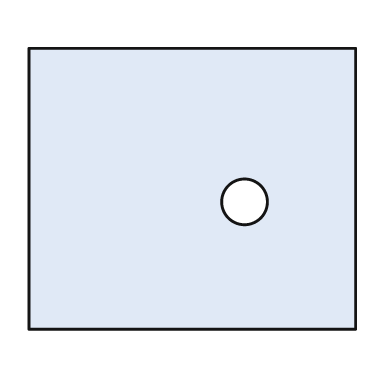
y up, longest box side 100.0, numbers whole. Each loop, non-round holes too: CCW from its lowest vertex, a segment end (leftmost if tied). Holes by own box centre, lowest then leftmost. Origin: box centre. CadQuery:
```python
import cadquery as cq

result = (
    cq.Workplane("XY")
    .moveTo(-50.0, -43.0)
    .lineTo(50.0, -43.0)
    .lineTo(50.0, 43.0)
    .lineTo(-50.0, 43.0)
    .close()
    .moveTo(16.0, -4.0)
    .circle(7.0)
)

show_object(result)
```